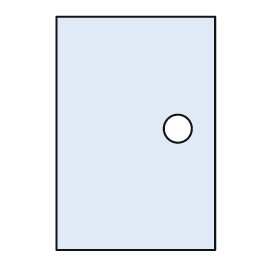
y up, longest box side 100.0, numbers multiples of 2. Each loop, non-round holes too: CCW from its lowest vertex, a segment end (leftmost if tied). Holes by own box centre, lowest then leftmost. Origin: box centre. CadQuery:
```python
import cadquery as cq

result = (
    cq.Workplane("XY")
    .moveTo(-34.0, -50.0)
    .lineTo(34.0, -50.0)
    .lineTo(34.0, 50.0)
    .lineTo(-34.0, 50.0)
    .close()
    .moveTo(18.0, 2.0)
    .circle(6.0)
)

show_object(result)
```